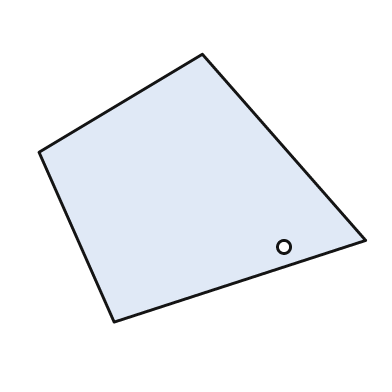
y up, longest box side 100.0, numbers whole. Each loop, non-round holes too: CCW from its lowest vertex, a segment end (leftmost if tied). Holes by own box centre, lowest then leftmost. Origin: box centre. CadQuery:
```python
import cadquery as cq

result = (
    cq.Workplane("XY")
    .moveTo(-27.0, -41.0)
    .lineTo(50.0, -16.0)
    .lineTo(0.0, 41.0)
    .lineTo(-50.0, 11.0)
    .close()
    .moveTo(25.0, -18.0)
    .circle(2.0)
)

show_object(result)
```